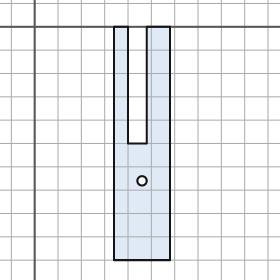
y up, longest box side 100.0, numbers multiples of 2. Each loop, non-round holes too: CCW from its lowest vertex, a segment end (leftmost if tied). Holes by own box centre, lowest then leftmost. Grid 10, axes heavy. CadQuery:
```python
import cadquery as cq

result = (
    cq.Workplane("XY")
    .moveTo(34.0, -100.0)
    .lineTo(58.0, -100.0)
    .lineTo(58.0, 0.0)
    .lineTo(48.0, 0.0)
    .lineTo(48.0, -50.0)
    .lineTo(40.0, -50.0)
    .lineTo(40.0, 0.0)
    .lineTo(34.0, 0.0)
    .close()
    .moveTo(46.0, -66.0)
    .circle(2.0)
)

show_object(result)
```